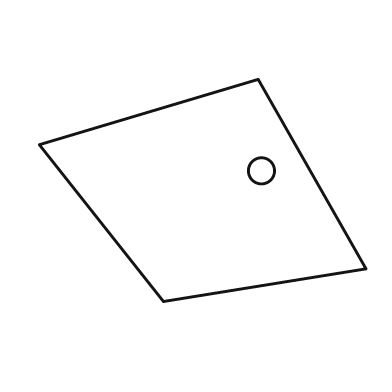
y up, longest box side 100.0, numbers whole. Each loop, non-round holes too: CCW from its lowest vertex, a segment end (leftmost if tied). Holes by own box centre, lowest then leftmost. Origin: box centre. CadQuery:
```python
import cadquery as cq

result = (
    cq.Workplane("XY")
    .moveTo(-12.0, -34.0)
    .lineTo(50.0, -24.0)
    .lineTo(17.0, 34.0)
    .lineTo(-50.0, 14.0)
    .close()
    .moveTo(18.0, 6.0)
    .circle(4.0)
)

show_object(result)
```